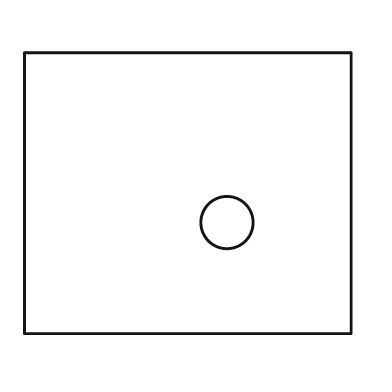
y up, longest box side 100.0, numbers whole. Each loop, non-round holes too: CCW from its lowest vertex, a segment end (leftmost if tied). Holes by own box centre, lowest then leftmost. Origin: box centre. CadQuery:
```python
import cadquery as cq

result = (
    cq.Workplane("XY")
    .moveTo(-50.0, -43.0)
    .lineTo(50.0, -43.0)
    .lineTo(50.0, 43.0)
    .lineTo(-50.0, 43.0)
    .close()
    .moveTo(12.0, -9.0)
    .circle(8.0)
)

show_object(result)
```